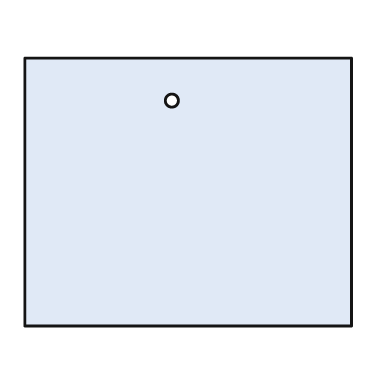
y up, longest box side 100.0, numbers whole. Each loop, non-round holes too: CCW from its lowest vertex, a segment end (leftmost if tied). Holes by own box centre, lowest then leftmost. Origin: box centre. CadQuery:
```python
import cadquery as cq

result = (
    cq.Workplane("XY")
    .moveTo(-50.0, -41.0)
    .lineTo(50.0, -41.0)
    .lineTo(50.0, 41.0)
    .lineTo(-50.0, 41.0)
    .close()
    .moveTo(-5.0, 28.0)
    .circle(2.0)
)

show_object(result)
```